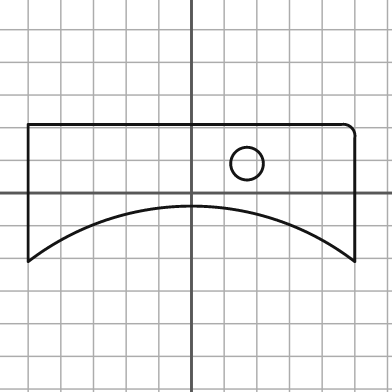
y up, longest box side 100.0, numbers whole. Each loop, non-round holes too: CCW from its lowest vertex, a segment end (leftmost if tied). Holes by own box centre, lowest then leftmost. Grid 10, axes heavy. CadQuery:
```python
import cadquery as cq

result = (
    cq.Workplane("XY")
    .moveTo(-50.0, -21.0)
    .threePointArc((0.0, -4.0), (50.0, -21.0))
    .lineTo(50.0, 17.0)
    .threePointArc((49.0, 20.0), (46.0, 21.0))
    .lineTo(-50.0, 21.0)
    .close()
    .moveTo(17.0, 9.0)
    .circle(5.0)
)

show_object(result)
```